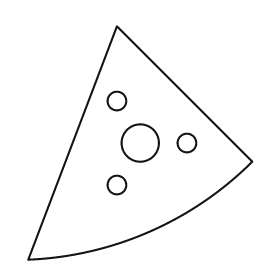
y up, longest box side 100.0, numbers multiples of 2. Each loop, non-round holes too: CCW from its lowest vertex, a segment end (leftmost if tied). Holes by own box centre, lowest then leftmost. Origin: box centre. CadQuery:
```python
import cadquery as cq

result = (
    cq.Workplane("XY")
    .moveTo(-48.0, -50.0)
    .threePointArc((4.0, -38.0), (48.0, -8.0))
    .lineTo(-10.0, 50.0)
    .close()
    .moveTo(-10.0, -18.0)
    .circle(4.0)
    .moveTo(0.0, 0.0)
    .circle(8.0)
    .moveTo(20.0, 0.0)
    .circle(4.0)
    .moveTo(-10.0, 18.0)
    .circle(4.0)
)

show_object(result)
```